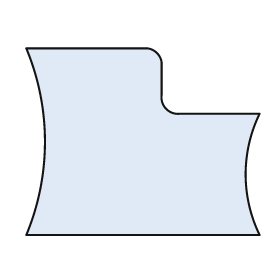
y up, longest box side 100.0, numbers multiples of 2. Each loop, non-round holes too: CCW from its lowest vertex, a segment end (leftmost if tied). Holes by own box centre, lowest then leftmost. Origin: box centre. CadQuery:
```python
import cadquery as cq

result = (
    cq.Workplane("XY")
    .moveTo(-50.0, -40.0)
    .lineTo(50.0, -40.0)
    .threePointArc((44.0, -14.0), (50.0, 12.0))
    .lineTo(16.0, 12.0)
    .threePointArc((10.0, 14.0), (8.0, 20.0))
    .lineTo(8.0, 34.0)
    .threePointArc((6.0, 38.0), (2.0, 40.0))
    .lineTo(-50.0, 40.0)
    .threePointArc((-42.0, 0.0), (-50.0, -40.0))
    .close()
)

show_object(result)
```